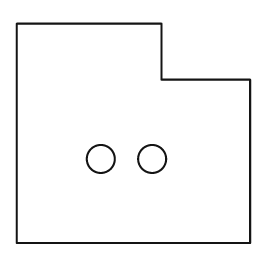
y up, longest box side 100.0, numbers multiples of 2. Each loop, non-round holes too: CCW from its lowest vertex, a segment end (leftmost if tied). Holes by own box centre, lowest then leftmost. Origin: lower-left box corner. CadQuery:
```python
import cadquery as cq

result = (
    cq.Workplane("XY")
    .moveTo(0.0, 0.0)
    .lineTo(100.0, 0.0)
    .lineTo(100.0, 70.0)
    .lineTo(62.0, 70.0)
    .lineTo(62.0, 94.0)
    .lineTo(0.0, 94.0)
    .close()
    .moveTo(36.0, 36.0)
    .circle(6.0)
    .moveTo(58.0, 36.0)
    .circle(6.0)
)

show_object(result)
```